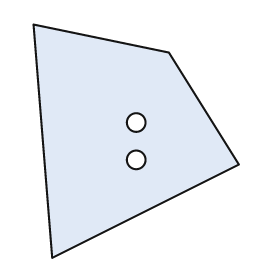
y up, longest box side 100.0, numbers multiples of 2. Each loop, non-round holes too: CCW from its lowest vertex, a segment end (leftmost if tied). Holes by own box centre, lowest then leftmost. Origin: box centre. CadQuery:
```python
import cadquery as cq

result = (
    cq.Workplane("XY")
    .moveTo(-36.0, -50.0)
    .lineTo(44.0, -10.0)
    .lineTo(14.0, 38.0)
    .lineTo(-44.0, 50.0)
    .close()
    .moveTo(0.0, -8.0)
    .circle(4.0)
    .moveTo(0.0, 8.0)
    .circle(4.0)
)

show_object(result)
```